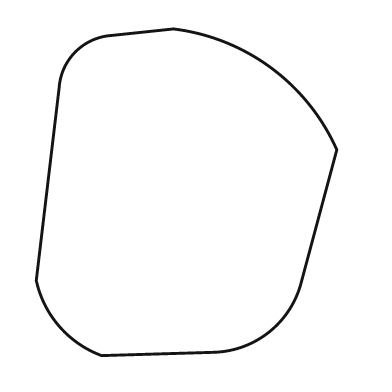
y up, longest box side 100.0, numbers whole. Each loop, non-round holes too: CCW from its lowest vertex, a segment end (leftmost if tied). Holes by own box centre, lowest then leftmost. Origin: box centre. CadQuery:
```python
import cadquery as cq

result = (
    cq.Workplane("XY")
    .moveTo(-26.0, -50.0)
    .lineTo(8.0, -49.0)
    .threePointArc((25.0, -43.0), (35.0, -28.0))
    .lineTo(46.0, 13.0)
    .threePointArc((26.0, 38.0), (-4.0, 50.0))
    .lineTo(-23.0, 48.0)
    .threePointArc((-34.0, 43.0), (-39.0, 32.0))
    .lineTo(-46.0, -27.0)
    .threePointArc((-39.0, -41.0), (-26.0, -50.0))
    .close()
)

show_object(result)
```